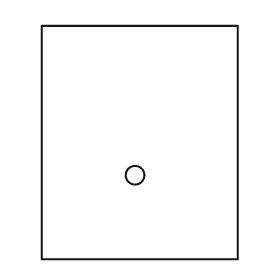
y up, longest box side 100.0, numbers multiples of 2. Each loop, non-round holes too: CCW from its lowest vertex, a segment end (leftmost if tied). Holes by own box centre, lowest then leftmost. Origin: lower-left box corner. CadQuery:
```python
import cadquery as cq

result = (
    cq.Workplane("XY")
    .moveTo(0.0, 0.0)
    .lineTo(84.0, 0.0)
    .lineTo(84.0, 100.0)
    .lineTo(0.0, 100.0)
    .close()
    .moveTo(40.0, 36.0)
    .circle(4.0)
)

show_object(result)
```